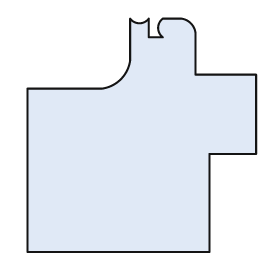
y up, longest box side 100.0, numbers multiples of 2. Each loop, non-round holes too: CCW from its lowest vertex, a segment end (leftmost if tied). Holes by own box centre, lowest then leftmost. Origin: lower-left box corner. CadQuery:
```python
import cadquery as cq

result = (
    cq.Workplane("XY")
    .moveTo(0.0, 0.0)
    .lineTo(78.0, 0.0)
    .lineTo(78.0, 42.0)
    .lineTo(98.0, 42.0)
    .lineTo(98.0, 76.0)
    .lineTo(72.0, 76.0)
    .lineTo(72.0, 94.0)
    .threePointArc((70.0, 98.0), (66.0, 100.0))
    .lineTo(58.0, 100.0)
    .threePointArc((56.0, 96.0), (58.0, 92.0))
    .lineTo(52.0, 92.0)
    .lineTo(52.0, 100.0)
    .threePointArc((48.0, 98.0), (44.0, 100.0))
    .lineTo(44.0, 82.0)
    .threePointArc((40.0, 74.0), (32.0, 70.0))
    .lineTo(0.0, 70.0)
    .close()
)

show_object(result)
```